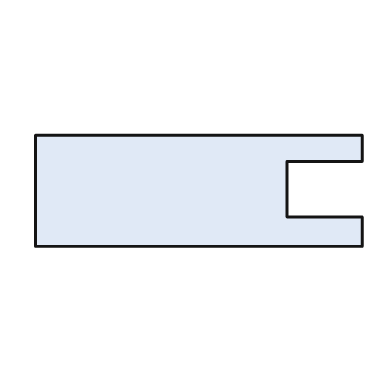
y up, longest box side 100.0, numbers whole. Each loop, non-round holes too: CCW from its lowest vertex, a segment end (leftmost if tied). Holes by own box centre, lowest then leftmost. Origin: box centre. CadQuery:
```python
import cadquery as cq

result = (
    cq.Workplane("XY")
    .moveTo(-50.0, -17.0)
    .lineTo(50.0, -17.0)
    .lineTo(50.0, -8.0)
    .lineTo(27.0, -8.0)
    .lineTo(27.0, 9.0)
    .lineTo(50.0, 9.0)
    .lineTo(50.0, 17.0)
    .lineTo(-50.0, 17.0)
    .close()
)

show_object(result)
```